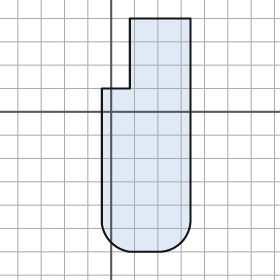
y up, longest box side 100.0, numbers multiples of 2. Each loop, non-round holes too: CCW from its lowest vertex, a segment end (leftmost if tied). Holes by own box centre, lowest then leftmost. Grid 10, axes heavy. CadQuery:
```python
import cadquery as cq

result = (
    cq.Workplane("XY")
    .moveTo(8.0, -60.0)
    .lineTo(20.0, -60.0)
    .threePointArc((30.0, -56.0), (34.0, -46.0))
    .lineTo(34.0, 40.0)
    .lineTo(8.0, 40.0)
    .lineTo(8.0, 10.0)
    .lineTo(-4.0, 10.0)
    .lineTo(-4.0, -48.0)
    .threePointArc((0.0, -56.0), (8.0, -60.0))
    .close()
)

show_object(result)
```